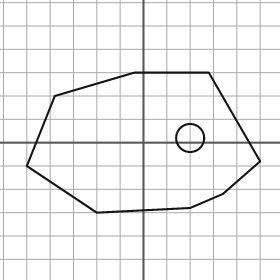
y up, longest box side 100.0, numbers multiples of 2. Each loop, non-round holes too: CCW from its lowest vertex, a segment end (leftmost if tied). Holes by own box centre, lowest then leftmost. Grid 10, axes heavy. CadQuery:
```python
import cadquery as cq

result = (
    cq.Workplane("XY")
    .moveTo(-20.0, -30.0)
    .lineTo(20.0, -28.0)
    .lineTo(34.0, -22.0)
    .lineTo(50.0, -8.0)
    .lineTo(28.0, 30.0)
    .lineTo(-4.0, 30.0)
    .lineTo(-38.0, 20.0)
    .lineTo(-50.0, -10.0)
    .close()
    .moveTo(20.0, 2.0)
    .circle(6.0)
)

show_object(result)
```